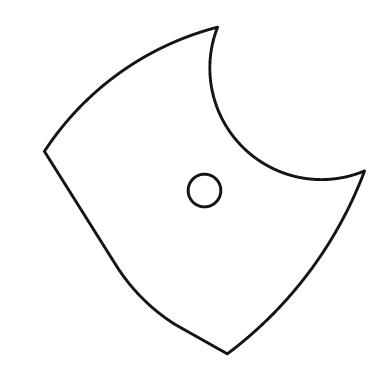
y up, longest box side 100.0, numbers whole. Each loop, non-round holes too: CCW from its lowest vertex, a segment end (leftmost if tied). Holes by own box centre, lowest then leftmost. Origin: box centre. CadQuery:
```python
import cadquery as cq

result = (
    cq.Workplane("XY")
    .moveTo(7.0, -50.0)
    .threePointArc((32.0, -25.0), (49.0, 6.0))
    .threePointArc((12.0, 13.0), (4.0, 50.0))
    .threePointArc((-26.0, 36.0), (-49.0, 12.0))
    .lineTo(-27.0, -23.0)
    .threePointArc((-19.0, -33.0), (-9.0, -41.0))
    .close()
    .moveTo(0.0, 0.0)
    .circle(5.0)
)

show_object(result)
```